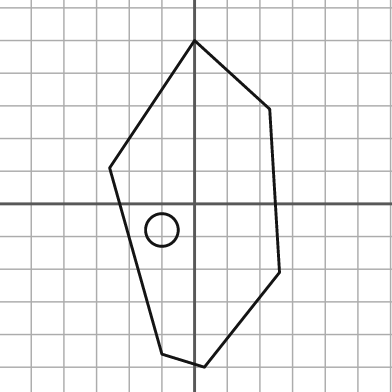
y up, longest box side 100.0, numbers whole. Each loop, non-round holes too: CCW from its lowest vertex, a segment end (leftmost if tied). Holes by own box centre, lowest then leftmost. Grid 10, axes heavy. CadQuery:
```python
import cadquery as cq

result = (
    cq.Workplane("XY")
    .moveTo(3.0, -50.0)
    .lineTo(26.0, -21.0)
    .lineTo(23.0, 29.0)
    .lineTo(0.0, 50.0)
    .lineTo(-26.0, 11.0)
    .lineTo(-10.0, -46.0)
    .close()
    .moveTo(-10.0, -8.0)
    .circle(5.0)
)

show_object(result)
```